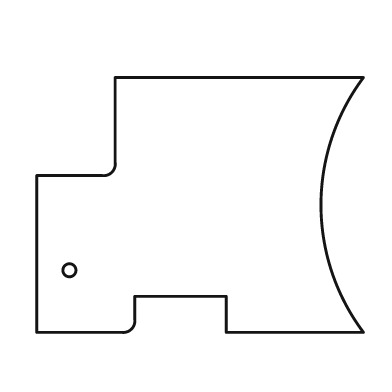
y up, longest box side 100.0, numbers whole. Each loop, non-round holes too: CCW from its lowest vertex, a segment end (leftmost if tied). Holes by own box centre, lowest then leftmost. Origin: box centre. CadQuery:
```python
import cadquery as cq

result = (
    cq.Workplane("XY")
    .moveTo(-50.0, -39.0)
    .lineTo(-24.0, -39.0)
    .threePointArc((-21.0, -38.0), (-20.0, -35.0))
    .lineTo(-20.0, -28.0)
    .lineTo(8.0, -28.0)
    .lineTo(8.0, -39.0)
    .lineTo(50.0, -39.0)
    .threePointArc((37.0, 0.0), (50.0, 39.0))
    .lineTo(-26.0, 39.0)
    .lineTo(-26.0, 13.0)
    .threePointArc((-27.0, 10.0), (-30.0, 9.0))
    .lineTo(-50.0, 9.0)
    .close()
    .moveTo(-40.0, -20.0)
    .circle(2.0)
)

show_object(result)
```